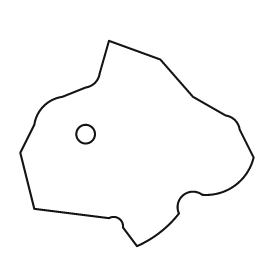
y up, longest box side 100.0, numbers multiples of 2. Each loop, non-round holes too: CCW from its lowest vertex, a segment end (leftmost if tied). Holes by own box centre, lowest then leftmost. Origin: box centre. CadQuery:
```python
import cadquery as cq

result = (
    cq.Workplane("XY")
    .moveTo(0.0, -44.0)
    .threePointArc((10.0, -38.0), (18.0, -30.0))
    .threePointArc((20.0, -22.0), (28.0, -22.0))
    .threePointArc((42.0, -18.0), (50.0, -6.0))
    .lineTo(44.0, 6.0)
    .threePointArc((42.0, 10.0), (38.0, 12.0))
    .lineTo(24.0, 20.0)
    .lineTo(10.0, 36.0)
    .lineTo(-12.0, 44.0)
    .lineTo(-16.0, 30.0)
    .threePointArc((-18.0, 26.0), (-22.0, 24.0))
    .lineTo(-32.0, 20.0)
    .threePointArc((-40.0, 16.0), (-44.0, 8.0))
    .lineTo(-50.0, -4.0)
    .lineTo(-44.0, -28.0)
    .lineTo(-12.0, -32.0)
    .threePointArc((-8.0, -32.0), (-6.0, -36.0))
    .close()
    .moveTo(-22.0, 4.0)
    .circle(4.0)
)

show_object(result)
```